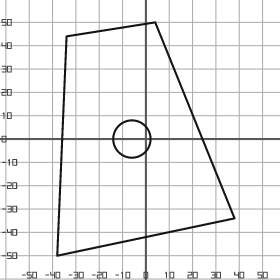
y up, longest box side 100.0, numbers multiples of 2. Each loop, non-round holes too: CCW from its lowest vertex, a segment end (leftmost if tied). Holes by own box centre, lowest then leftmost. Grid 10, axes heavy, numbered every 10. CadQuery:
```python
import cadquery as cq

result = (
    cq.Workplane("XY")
    .moveTo(-38.0, -50.0)
    .lineTo(38.0, -34.0)
    .lineTo(4.0, 50.0)
    .lineTo(-34.0, 44.0)
    .close()
    .moveTo(-6.0, 0.0)
    .circle(8.0)
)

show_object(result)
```